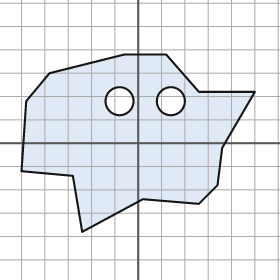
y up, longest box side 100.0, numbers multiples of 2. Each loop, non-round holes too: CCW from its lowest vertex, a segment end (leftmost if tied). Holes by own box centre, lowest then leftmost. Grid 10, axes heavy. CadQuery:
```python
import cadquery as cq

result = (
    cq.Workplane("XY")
    .moveTo(-24.0, -38.0)
    .lineTo(2.0, -24.0)
    .lineTo(26.0, -26.0)
    .lineTo(34.0, -18.0)
    .lineTo(36.0, -2.0)
    .lineTo(50.0, 22.0)
    .lineTo(26.0, 22.0)
    .lineTo(12.0, 38.0)
    .lineTo(-6.0, 38.0)
    .lineTo(-38.0, 30.0)
    .lineTo(-48.0, 18.0)
    .lineTo(-50.0, -12.0)
    .lineTo(-28.0, -14.0)
    .close()
    .moveTo(-8.0, 18.0)
    .circle(6.0)
    .moveTo(14.0, 18.0)
    .circle(6.0)
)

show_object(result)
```